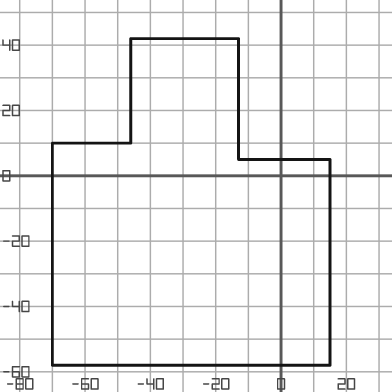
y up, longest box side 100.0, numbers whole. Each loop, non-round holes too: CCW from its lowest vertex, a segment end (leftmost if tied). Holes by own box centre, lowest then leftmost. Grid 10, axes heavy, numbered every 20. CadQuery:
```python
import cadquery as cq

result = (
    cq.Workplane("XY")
    .moveTo(-70.0, -58.0)
    .lineTo(15.0, -58.0)
    .lineTo(15.0, 5.0)
    .lineTo(-13.0, 5.0)
    .lineTo(-13.0, 42.0)
    .lineTo(-46.0, 42.0)
    .lineTo(-46.0, 10.0)
    .lineTo(-70.0, 10.0)
    .close()
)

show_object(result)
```